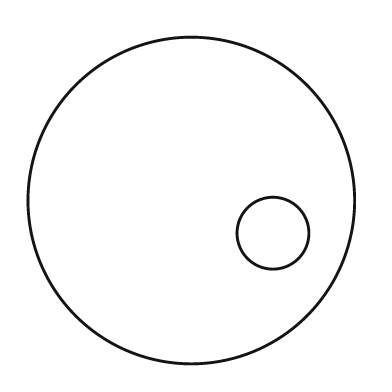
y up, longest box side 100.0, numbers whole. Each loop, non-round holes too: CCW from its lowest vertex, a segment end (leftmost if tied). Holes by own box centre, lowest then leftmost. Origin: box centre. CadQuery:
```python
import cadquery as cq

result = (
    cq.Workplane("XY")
    .moveTo(0.0, 0.0)
    .circle(50.0)
    .moveTo(25.0, -10.0)
    .circle(11.0)
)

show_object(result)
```